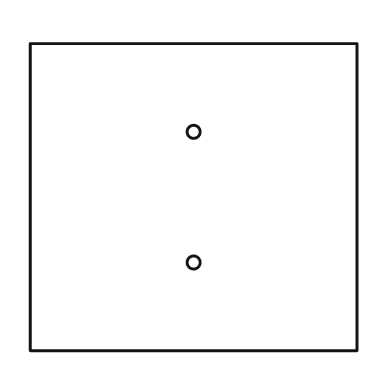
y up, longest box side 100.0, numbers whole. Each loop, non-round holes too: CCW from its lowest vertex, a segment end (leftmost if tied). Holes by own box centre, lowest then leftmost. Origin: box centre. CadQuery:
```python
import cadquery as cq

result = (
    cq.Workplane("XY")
    .moveTo(-50.0, -47.0)
    .lineTo(50.0, -47.0)
    .lineTo(50.0, 47.0)
    .lineTo(-50.0, 47.0)
    .close()
    .moveTo(0.0, -20.0)
    .circle(2.0)
    .moveTo(0.0, 20.0)
    .circle(2.0)
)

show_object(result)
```